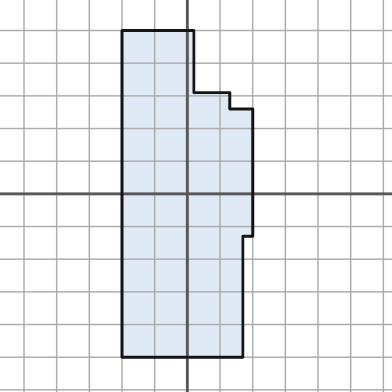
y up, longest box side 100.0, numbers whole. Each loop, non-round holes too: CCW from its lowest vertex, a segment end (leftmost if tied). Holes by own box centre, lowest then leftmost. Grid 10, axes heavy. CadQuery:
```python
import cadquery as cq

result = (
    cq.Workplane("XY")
    .moveTo(-20.0, -50.0)
    .lineTo(17.0, -50.0)
    .lineTo(17.0, -13.0)
    .lineTo(20.0, -13.0)
    .lineTo(20.0, 26.0)
    .lineTo(13.0, 26.0)
    .lineTo(13.0, 31.0)
    .lineTo(2.0, 31.0)
    .lineTo(2.0, 50.0)
    .lineTo(-20.0, 50.0)
    .close()
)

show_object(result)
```